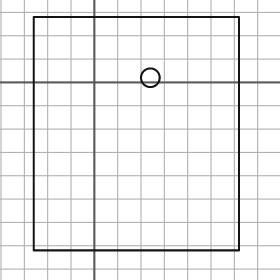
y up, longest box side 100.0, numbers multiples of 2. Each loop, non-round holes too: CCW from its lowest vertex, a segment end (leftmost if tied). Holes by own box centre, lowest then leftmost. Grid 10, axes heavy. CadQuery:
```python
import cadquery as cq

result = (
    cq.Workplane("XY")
    .moveTo(-26.0, -72.0)
    .lineTo(62.0, -72.0)
    .lineTo(62.0, 28.0)
    .lineTo(-26.0, 28.0)
    .close()
    .moveTo(24.0, 2.0)
    .circle(4.0)
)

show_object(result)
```